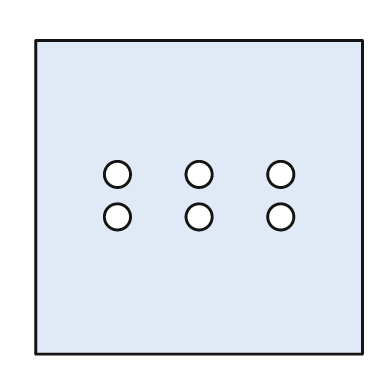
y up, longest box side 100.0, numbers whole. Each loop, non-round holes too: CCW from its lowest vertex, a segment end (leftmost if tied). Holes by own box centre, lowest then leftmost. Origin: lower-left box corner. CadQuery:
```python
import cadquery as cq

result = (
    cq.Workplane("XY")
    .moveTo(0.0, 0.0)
    .lineTo(100.0, 0.0)
    .lineTo(100.0, 96.0)
    .lineTo(0.0, 96.0)
    .close()
    .moveTo(25.0, 42.0)
    .circle(4.0)
    .moveTo(50.0, 42.0)
    .circle(4.0)
    .moveTo(75.0, 42.0)
    .circle(4.0)
    .moveTo(25.0, 55.0)
    .circle(4.0)
    .moveTo(50.0, 55.0)
    .circle(4.0)
    .moveTo(75.0, 55.0)
    .circle(4.0)
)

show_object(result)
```